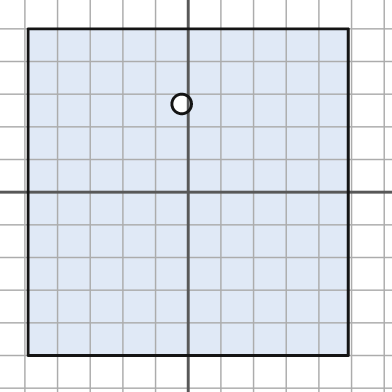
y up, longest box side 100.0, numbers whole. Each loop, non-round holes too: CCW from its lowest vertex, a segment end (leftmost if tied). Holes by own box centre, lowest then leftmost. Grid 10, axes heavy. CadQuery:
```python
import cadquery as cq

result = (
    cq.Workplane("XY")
    .moveTo(-49.0, -50.0)
    .lineTo(49.0, -50.0)
    .lineTo(49.0, 50.0)
    .lineTo(-49.0, 50.0)
    .close()
    .moveTo(-2.0, 27.0)
    .circle(3.0)
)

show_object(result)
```